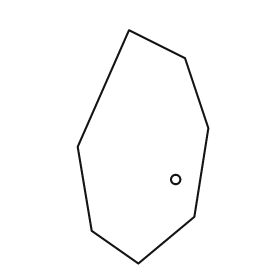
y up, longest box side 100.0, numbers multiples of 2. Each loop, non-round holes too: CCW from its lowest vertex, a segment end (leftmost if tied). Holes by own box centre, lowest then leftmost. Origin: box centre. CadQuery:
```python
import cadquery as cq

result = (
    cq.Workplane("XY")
    .moveTo(-2.0, -50.0)
    .lineTo(22.0, -30.0)
    .lineTo(28.0, 8.0)
    .lineTo(18.0, 38.0)
    .lineTo(-6.0, 50.0)
    .lineTo(-28.0, 0.0)
    .lineTo(-22.0, -36.0)
    .close()
    .moveTo(14.0, -14.0)
    .circle(2.0)
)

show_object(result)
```